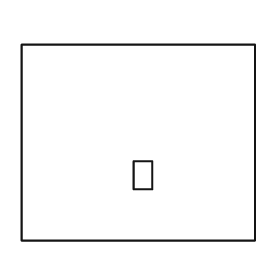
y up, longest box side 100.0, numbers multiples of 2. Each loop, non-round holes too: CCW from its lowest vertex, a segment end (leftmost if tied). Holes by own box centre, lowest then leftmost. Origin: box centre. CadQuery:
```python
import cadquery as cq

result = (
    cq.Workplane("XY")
    .moveTo(-50.0, -42.0)
    .lineTo(50.0, -42.0)
    .lineTo(50.0, 42.0)
    .lineTo(-50.0, 42.0)
    .close()
    .moveTo(-2.0, -20.0)
    .lineTo(6.0, -20.0)
    .lineTo(6.0, -8.0)
    .lineTo(-2.0, -8.0)
    .close()
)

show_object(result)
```